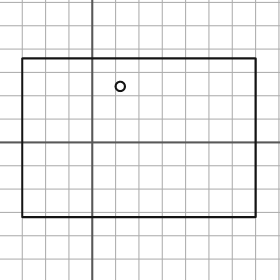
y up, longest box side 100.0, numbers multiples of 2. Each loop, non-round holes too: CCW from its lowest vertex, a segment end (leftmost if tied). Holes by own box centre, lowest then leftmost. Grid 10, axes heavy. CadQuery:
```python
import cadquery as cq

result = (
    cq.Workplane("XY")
    .moveTo(-30.0, -32.0)
    .lineTo(70.0, -32.0)
    .lineTo(70.0, 36.0)
    .lineTo(-30.0, 36.0)
    .close()
    .moveTo(12.0, 24.0)
    .circle(2.0)
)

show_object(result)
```